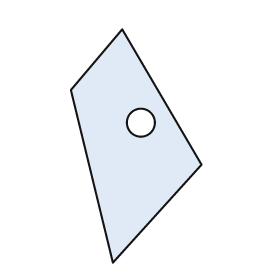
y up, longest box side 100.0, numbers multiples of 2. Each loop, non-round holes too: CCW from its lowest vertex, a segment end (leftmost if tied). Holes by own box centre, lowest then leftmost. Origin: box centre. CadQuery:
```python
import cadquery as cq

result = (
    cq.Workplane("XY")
    .moveTo(-10.0, -50.0)
    .lineTo(28.0, -8.0)
    .lineTo(-6.0, 50.0)
    .lineTo(-28.0, 24.0)
    .close()
    .moveTo(2.0, 10.0)
    .circle(6.0)
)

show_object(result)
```